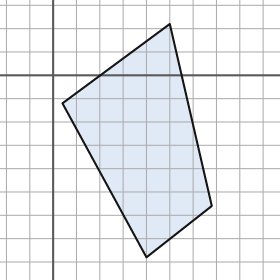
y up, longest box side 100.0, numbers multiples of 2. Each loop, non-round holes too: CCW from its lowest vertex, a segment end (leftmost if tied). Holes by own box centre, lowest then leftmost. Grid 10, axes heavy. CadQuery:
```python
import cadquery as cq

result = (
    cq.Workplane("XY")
    .moveTo(40.0, -78.0)
    .lineTo(68.0, -56.0)
    .lineTo(50.0, 22.0)
    .lineTo(4.0, -12.0)
    .close()
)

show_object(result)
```